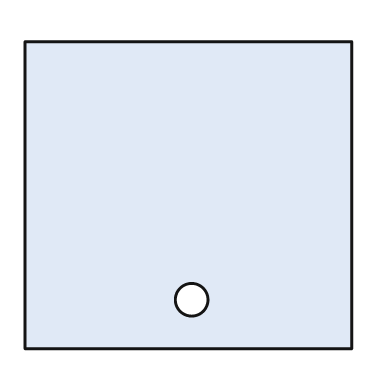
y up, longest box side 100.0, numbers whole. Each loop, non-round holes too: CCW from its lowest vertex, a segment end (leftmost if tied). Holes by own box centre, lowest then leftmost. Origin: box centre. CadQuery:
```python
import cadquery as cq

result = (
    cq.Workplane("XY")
    .moveTo(-50.0, -47.0)
    .lineTo(50.0, -47.0)
    .lineTo(50.0, 47.0)
    .lineTo(-50.0, 47.0)
    .close()
    .moveTo(1.0, -32.0)
    .circle(5.0)
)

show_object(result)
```